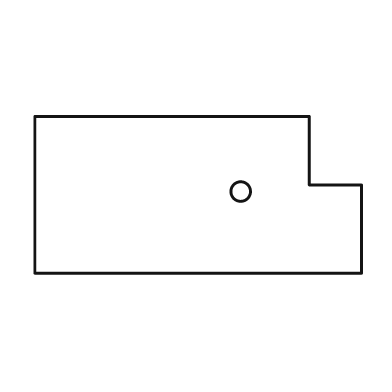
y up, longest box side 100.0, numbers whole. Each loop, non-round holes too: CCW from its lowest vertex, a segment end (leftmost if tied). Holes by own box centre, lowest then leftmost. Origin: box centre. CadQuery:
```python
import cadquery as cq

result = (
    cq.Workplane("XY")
    .moveTo(-50.0, -24.0)
    .lineTo(50.0, -24.0)
    .lineTo(50.0, 3.0)
    .lineTo(34.0, 3.0)
    .lineTo(34.0, 24.0)
    .lineTo(-50.0, 24.0)
    .close()
    .moveTo(13.0, 1.0)
    .circle(3.0)
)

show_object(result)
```